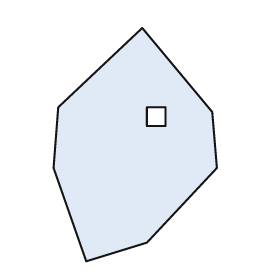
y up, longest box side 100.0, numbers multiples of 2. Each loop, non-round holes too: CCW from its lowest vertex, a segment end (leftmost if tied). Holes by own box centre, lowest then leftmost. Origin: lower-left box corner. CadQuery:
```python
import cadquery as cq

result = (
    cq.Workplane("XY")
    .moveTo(14.0, 0.0)
    .lineTo(40.0, 8.0)
    .lineTo(70.0, 40.0)
    .lineTo(68.0, 64.0)
    .lineTo(38.0, 100.0)
    .lineTo(2.0, 66.0)
    .lineTo(0.0, 40.0)
    .close()
    .moveTo(40.0, 58.0)
    .lineTo(48.0, 58.0)
    .lineTo(48.0, 66.0)
    .lineTo(40.0, 66.0)
    .close()
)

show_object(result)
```